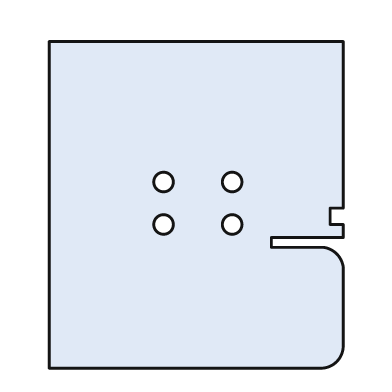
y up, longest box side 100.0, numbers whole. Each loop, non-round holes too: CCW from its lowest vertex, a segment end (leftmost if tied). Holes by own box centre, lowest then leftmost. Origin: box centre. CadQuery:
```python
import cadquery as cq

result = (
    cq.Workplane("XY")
    .moveTo(-45.0, -50.0)
    .lineTo(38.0, -50.0)
    .threePointArc((43.0, -48.0), (45.0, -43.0))
    .lineTo(45.0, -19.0)
    .threePointArc((43.0, -15.0), (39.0, -13.0))
    .lineTo(23.0, -13.0)
    .lineTo(23.0, -10.0)
    .lineTo(45.0, -10.0)
    .lineTo(45.0, -6.0)
    .lineTo(41.0, -6.0)
    .lineTo(41.0, -1.0)
    .lineTo(45.0, -1.0)
    .lineTo(45.0, 50.0)
    .lineTo(-45.0, 50.0)
    .close()
    .moveTo(-10.0, -6.0)
    .circle(3.0)
    .moveTo(11.0, -6.0)
    .circle(3.0)
    .moveTo(-10.0, 7.0)
    .circle(3.0)
    .moveTo(11.0, 7.0)
    .circle(3.0)
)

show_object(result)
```